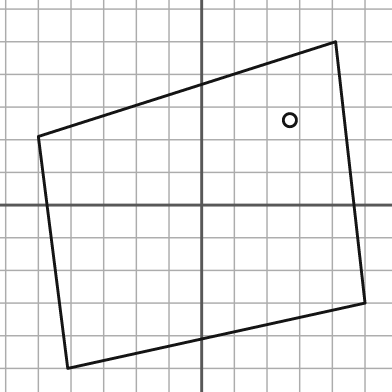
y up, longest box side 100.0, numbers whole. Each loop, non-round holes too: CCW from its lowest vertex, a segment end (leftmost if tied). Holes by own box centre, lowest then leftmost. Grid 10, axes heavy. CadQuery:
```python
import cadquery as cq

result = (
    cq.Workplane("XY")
    .moveTo(-41.0, -50.0)
    .lineTo(50.0, -30.0)
    .lineTo(41.0, 50.0)
    .lineTo(-50.0, 21.0)
    .close()
    .moveTo(27.0, 26.0)
    .circle(2.0)
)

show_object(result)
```